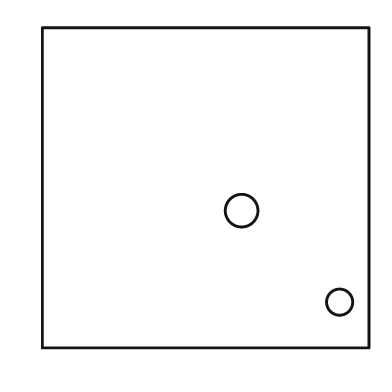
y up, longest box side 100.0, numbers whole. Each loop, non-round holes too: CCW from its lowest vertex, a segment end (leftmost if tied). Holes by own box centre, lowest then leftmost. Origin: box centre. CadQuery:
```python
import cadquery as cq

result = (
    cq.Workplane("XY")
    .moveTo(-50.0, -49.0)
    .lineTo(50.0, -49.0)
    .lineTo(50.0, 49.0)
    .lineTo(-50.0, 49.0)
    .close()
    .moveTo(41.0, -35.0)
    .circle(4.0)
    .moveTo(11.0, -7.0)
    .circle(5.0)
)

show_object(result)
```